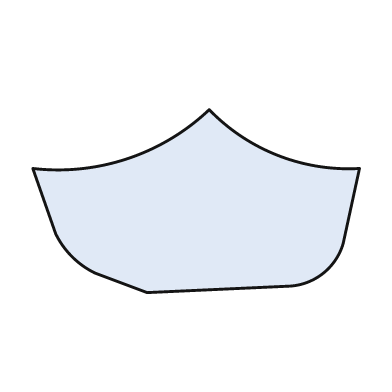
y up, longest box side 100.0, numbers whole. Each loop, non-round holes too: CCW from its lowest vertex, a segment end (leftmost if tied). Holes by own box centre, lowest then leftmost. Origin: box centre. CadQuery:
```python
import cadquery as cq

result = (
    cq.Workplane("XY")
    .moveTo(-15.0, -28.0)
    .lineTo(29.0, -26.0)
    .threePointArc((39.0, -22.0), (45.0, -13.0))
    .lineTo(50.0, 10.0)
    .threePointArc((25.0, 14.0), (4.0, 28.0))
    .threePointArc((-21.0, 13.0), (-50.0, 10.0))
    .lineTo(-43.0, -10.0)
    .threePointArc((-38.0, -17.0), (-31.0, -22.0))
    .close()
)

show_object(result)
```